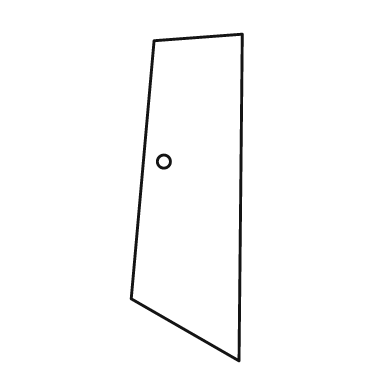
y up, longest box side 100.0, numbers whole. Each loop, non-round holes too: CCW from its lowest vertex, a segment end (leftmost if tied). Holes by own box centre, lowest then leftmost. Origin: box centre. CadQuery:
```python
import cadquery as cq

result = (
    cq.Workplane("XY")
    .moveTo(16.0, -50.0)
    .lineTo(17.0, 50.0)
    .lineTo(-10.0, 48.0)
    .lineTo(-17.0, -31.0)
    .close()
    .moveTo(-7.0, 11.0)
    .circle(2.0)
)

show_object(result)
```